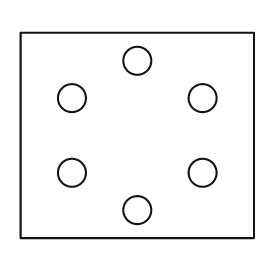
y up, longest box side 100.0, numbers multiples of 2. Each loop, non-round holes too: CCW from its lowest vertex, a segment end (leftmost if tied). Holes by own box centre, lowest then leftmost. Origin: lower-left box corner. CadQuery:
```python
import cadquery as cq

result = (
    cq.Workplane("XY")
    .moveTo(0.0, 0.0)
    .lineTo(100.0, 0.0)
    .lineTo(100.0, 88.0)
    .lineTo(0.0, 88.0)
    .close()
    .moveTo(50.0, 12.0)
    .circle(6.0)
    .moveTo(22.0, 28.0)
    .circle(6.0)
    .moveTo(78.0, 28.0)
    .circle(6.0)
    .moveTo(22.0, 60.0)
    .circle(6.0)
    .moveTo(78.0, 60.0)
    .circle(6.0)
    .moveTo(50.0, 76.0)
    .circle(6.0)
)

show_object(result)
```